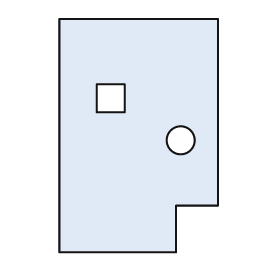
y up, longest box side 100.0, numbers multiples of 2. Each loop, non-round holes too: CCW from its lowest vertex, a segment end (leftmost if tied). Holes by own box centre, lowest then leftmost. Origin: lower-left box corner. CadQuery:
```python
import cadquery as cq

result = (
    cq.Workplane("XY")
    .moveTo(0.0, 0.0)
    .lineTo(50.0, 0.0)
    .lineTo(50.0, 20.0)
    .lineTo(68.0, 20.0)
    .lineTo(68.0, 100.0)
    .lineTo(0.0, 100.0)
    .close()
    .moveTo(52.0, 48.0)
    .circle(6.0)
    .moveTo(16.0, 60.0)
    .lineTo(28.0, 60.0)
    .lineTo(28.0, 72.0)
    .lineTo(16.0, 72.0)
    .close()
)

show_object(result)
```